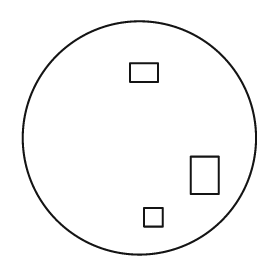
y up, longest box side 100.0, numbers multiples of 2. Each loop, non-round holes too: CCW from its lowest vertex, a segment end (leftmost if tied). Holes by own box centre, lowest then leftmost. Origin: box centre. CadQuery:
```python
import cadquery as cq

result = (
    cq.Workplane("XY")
    .moveTo(0.0, 0.0)
    .circle(50.0)
    .moveTo(2.0, -38.0)
    .lineTo(10.0, -38.0)
    .lineTo(10.0, -30.0)
    .lineTo(2.0, -30.0)
    .close()
    .moveTo(22.0, -24.0)
    .lineTo(34.0, -24.0)
    .lineTo(34.0, -8.0)
    .lineTo(22.0, -8.0)
    .close()
    .moveTo(-4.0, 24.0)
    .lineTo(8.0, 24.0)
    .lineTo(8.0, 32.0)
    .lineTo(-4.0, 32.0)
    .close()
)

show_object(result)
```